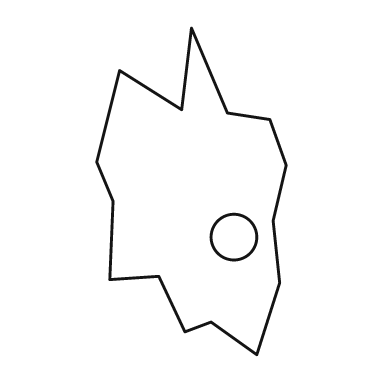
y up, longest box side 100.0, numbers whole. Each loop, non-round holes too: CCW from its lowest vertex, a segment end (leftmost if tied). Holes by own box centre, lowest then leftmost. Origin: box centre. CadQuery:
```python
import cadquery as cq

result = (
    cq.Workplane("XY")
    .moveTo(20.0, -50.0)
    .lineTo(27.0, -28.0)
    .lineTo(25.0, -9.0)
    .lineTo(29.0, 8.0)
    .lineTo(24.0, 22.0)
    .lineTo(11.0, 24.0)
    .lineTo(0.0, 50.0)
    .lineTo(-3.0, 25.0)
    .lineTo(-22.0, 37.0)
    .lineTo(-29.0, 9.0)
    .lineTo(-24.0, -3.0)
    .lineTo(-25.0, -27.0)
    .lineTo(-10.0, -26.0)
    .lineTo(-2.0, -43.0)
    .lineTo(6.0, -40.0)
    .close()
    .moveTo(13.0, -14.0)
    .circle(7.0)
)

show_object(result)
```